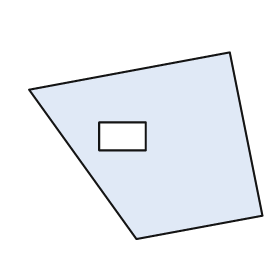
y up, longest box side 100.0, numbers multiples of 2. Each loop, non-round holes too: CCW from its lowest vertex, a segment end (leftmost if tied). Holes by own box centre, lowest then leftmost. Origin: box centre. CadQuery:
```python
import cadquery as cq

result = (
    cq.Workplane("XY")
    .moveTo(-4.0, -40.0)
    .lineTo(50.0, -30.0)
    .lineTo(36.0, 40.0)
    .lineTo(-50.0, 24.0)
    .close()
    .moveTo(-20.0, -2.0)
    .lineTo(0.0, -2.0)
    .lineTo(0.0, 10.0)
    .lineTo(-20.0, 10.0)
    .close()
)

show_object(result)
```